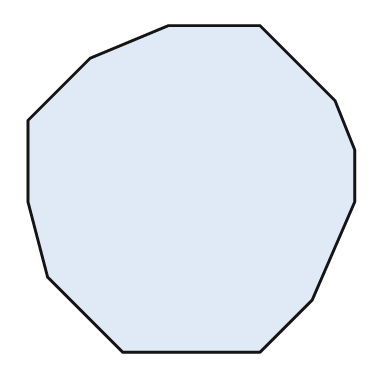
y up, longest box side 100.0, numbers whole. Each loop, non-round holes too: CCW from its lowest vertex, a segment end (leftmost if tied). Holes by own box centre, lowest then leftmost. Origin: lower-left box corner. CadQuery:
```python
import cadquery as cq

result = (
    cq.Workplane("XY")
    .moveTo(29.0, 0.0)
    .lineTo(71.0, 0.0)
    .lineTo(87.0, 16.0)
    .lineTo(100.0, 46.0)
    .lineTo(100.0, 62.0)
    .lineTo(94.0, 77.0)
    .lineTo(71.0, 100.0)
    .lineTo(43.0, 100.0)
    .lineTo(19.0, 90.0)
    .lineTo(0.0, 71.0)
    .lineTo(0.0, 46.0)
    .lineTo(6.0, 23.0)
    .close()
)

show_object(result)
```